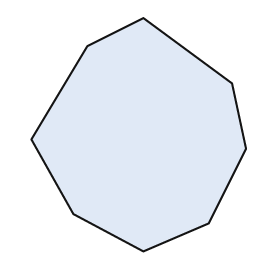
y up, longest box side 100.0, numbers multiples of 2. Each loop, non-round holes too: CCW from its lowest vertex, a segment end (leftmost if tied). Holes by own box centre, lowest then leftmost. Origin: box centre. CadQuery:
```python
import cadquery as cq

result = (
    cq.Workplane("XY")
    .moveTo(2.0, -50.0)
    .lineTo(30.0, -38.0)
    .lineTo(46.0, -6.0)
    .lineTo(40.0, 22.0)
    .lineTo(2.0, 50.0)
    .lineTo(-22.0, 38.0)
    .lineTo(-46.0, -2.0)
    .lineTo(-28.0, -34.0)
    .close()
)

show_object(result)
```